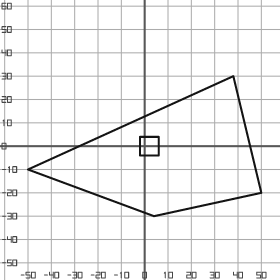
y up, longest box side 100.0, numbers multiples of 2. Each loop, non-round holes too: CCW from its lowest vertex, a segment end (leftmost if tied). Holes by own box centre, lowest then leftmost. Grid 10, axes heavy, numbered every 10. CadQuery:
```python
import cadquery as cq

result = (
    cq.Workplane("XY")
    .moveTo(4.0, -30.0)
    .lineTo(50.0, -20.0)
    .lineTo(38.0, 30.0)
    .lineTo(-50.0, -10.0)
    .close()
    .moveTo(-2.0, -4.0)
    .lineTo(6.0, -4.0)
    .lineTo(6.0, 4.0)
    .lineTo(-2.0, 4.0)
    .close()
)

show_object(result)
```